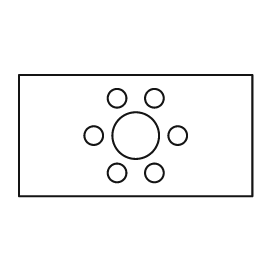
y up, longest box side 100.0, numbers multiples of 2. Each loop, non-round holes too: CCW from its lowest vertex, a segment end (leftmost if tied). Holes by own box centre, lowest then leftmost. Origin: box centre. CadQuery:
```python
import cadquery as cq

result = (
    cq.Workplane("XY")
    .moveTo(-50.0, -26.0)
    .lineTo(50.0, -26.0)
    .lineTo(50.0, 26.0)
    .lineTo(-50.0, 26.0)
    .close()
    .moveTo(-8.0, -16.0)
    .circle(4.0)
    .moveTo(8.0, -16.0)
    .circle(4.0)
    .moveTo(-18.0, 0.0)
    .circle(4.0)
    .moveTo(0.0, 0.0)
    .circle(10.0)
    .moveTo(18.0, 0.0)
    .circle(4.0)
    .moveTo(-8.0, 16.0)
    .circle(4.0)
    .moveTo(8.0, 16.0)
    .circle(4.0)
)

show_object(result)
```